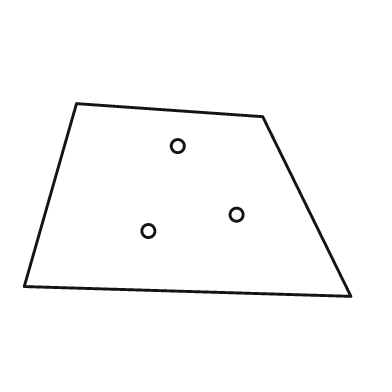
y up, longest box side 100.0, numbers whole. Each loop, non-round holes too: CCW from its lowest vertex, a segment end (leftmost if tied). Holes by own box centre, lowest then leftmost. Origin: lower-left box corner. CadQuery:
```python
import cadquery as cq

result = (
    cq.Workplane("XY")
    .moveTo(100.0, 0.0)
    .lineTo(73.0, 55.0)
    .lineTo(16.0, 59.0)
    .lineTo(0.0, 3.0)
    .close()
    .moveTo(38.0, 20.0)
    .circle(2.0)
    .moveTo(65.0, 25.0)
    .circle(2.0)
    .moveTo(47.0, 46.0)
    .circle(2.0)
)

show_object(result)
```